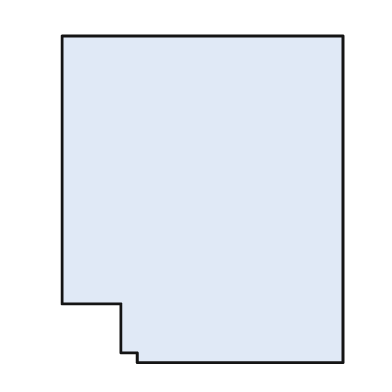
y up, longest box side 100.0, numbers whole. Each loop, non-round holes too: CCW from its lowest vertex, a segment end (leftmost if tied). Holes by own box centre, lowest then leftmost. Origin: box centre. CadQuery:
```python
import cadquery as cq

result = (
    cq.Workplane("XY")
    .moveTo(-20.0, -50.0)
    .lineTo(43.0, -50.0)
    .lineTo(43.0, 50.0)
    .lineTo(-43.0, 50.0)
    .lineTo(-43.0, -32.0)
    .lineTo(-25.0, -32.0)
    .lineTo(-25.0, -47.0)
    .lineTo(-20.0, -47.0)
    .close()
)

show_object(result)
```